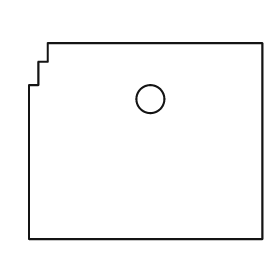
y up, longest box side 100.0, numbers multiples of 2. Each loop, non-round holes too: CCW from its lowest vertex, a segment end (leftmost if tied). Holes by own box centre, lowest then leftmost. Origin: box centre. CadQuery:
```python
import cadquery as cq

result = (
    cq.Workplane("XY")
    .moveTo(-50.0, -42.0)
    .lineTo(50.0, -42.0)
    .lineTo(50.0, 42.0)
    .lineTo(-42.0, 42.0)
    .lineTo(-42.0, 34.0)
    .lineTo(-46.0, 34.0)
    .lineTo(-46.0, 24.0)
    .lineTo(-50.0, 24.0)
    .close()
    .moveTo(2.0, 18.0)
    .circle(6.0)
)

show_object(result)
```